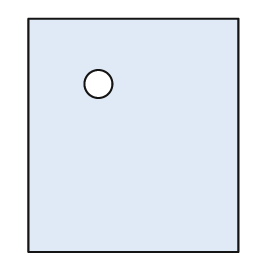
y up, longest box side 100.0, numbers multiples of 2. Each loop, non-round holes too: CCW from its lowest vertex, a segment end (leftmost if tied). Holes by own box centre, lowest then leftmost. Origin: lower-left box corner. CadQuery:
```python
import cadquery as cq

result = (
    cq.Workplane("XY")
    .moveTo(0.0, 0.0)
    .lineTo(90.0, 0.0)
    .lineTo(90.0, 100.0)
    .lineTo(0.0, 100.0)
    .close()
    .moveTo(30.0, 72.0)
    .circle(6.0)
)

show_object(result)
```